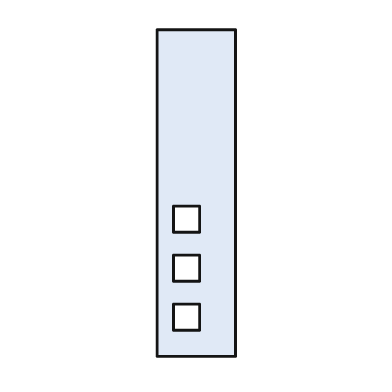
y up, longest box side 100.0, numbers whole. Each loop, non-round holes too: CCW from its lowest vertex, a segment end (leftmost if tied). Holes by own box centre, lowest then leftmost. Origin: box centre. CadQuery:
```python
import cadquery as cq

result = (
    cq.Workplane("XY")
    .moveTo(-12.0, -50.0)
    .lineTo(12.0, -50.0)
    .lineTo(12.0, 50.0)
    .lineTo(-12.0, 50.0)
    .close()
    .moveTo(-7.0, -42.0)
    .lineTo(1.0, -42.0)
    .lineTo(1.0, -34.0)
    .lineTo(-7.0, -34.0)
    .close()
    .moveTo(-7.0, -27.0)
    .lineTo(1.0, -27.0)
    .lineTo(1.0, -19.0)
    .lineTo(-7.0, -19.0)
    .close()
    .moveTo(-7.0, -12.0)
    .lineTo(1.0, -12.0)
    .lineTo(1.0, -4.0)
    .lineTo(-7.0, -4.0)
    .close()
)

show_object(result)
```